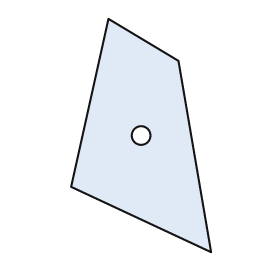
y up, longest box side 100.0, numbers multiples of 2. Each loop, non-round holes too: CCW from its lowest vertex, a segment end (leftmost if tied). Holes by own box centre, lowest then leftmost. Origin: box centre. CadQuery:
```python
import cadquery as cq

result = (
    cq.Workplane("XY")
    .moveTo(30.0, -50.0)
    .lineTo(16.0, 32.0)
    .lineTo(-14.0, 50.0)
    .lineTo(-30.0, -22.0)
    .close()
    .moveTo(0.0, 0.0)
    .circle(4.0)
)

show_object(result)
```